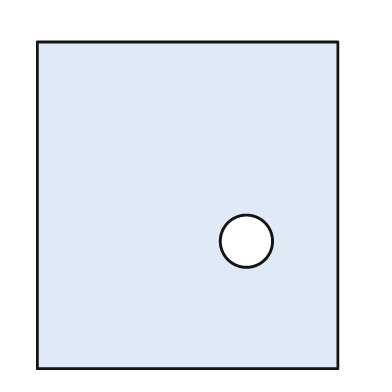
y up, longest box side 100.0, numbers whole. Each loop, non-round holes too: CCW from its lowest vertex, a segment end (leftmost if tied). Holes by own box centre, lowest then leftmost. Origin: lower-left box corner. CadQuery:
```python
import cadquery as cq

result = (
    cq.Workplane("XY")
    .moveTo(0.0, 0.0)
    .lineTo(92.0, 0.0)
    .lineTo(92.0, 100.0)
    .lineTo(0.0, 100.0)
    .close()
    .moveTo(64.0, 39.0)
    .circle(8.0)
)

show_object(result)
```